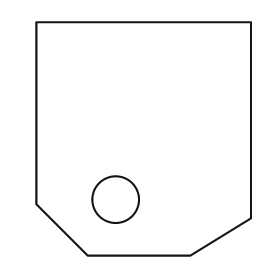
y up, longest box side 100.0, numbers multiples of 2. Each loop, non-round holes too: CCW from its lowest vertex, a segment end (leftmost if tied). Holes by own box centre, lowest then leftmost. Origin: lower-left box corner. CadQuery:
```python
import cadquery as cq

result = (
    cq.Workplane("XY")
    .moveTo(22.0, 0.0)
    .lineTo(66.0, 0.0)
    .lineTo(92.0, 16.0)
    .lineTo(92.0, 100.0)
    .lineTo(0.0, 100.0)
    .lineTo(0.0, 22.0)
    .close()
    .moveTo(34.0, 24.0)
    .circle(10.0)
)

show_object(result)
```